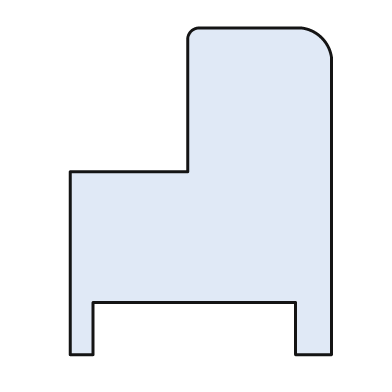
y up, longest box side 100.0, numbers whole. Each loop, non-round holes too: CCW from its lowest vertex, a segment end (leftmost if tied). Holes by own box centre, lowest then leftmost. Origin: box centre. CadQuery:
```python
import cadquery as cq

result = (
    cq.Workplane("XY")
    .moveTo(-40.0, -50.0)
    .lineTo(-33.0, -50.0)
    .lineTo(-33.0, -34.0)
    .lineTo(29.0, -34.0)
    .lineTo(29.0, -50.0)
    .lineTo(40.0, -50.0)
    .lineTo(40.0, 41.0)
    .threePointArc((37.0, 47.0), (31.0, 50.0))
    .lineTo(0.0, 50.0)
    .threePointArc((-3.0, 49.0), (-4.0, 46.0))
    .lineTo(-4.0, 6.0)
    .lineTo(-40.0, 6.0)
    .close()
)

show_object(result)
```